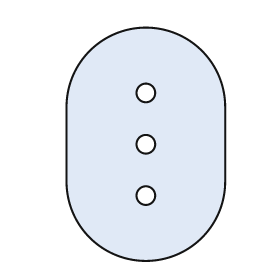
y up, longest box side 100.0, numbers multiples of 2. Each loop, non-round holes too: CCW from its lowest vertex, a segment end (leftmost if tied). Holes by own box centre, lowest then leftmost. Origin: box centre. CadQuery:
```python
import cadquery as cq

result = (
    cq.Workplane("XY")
    .moveTo(-34.0, -16.0)
    .threePointArc((0.0, -50.0), (34.0, -16.0))
    .lineTo(34.0, 16.0)
    .threePointArc((0.0, 50.0), (-34.0, 16.0))
    .close()
    .moveTo(0.0, -22.0)
    .circle(4.0)
    .moveTo(0.0, 0.0)
    .circle(4.0)
    .moveTo(0.0, 22.0)
    .circle(4.0)
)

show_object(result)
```